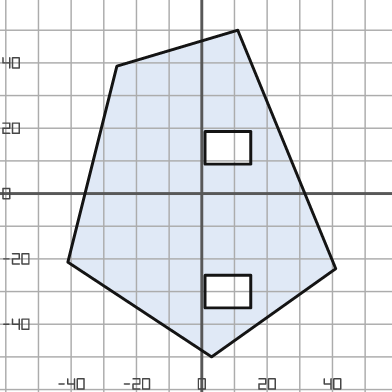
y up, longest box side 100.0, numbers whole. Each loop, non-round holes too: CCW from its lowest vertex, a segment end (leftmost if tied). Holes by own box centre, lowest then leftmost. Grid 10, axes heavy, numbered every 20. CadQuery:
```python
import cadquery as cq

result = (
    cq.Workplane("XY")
    .moveTo(3.0, -50.0)
    .lineTo(41.0, -23.0)
    .lineTo(11.0, 50.0)
    .lineTo(-26.0, 39.0)
    .lineTo(-41.0, -21.0)
    .close()
    .moveTo(1.0, -35.0)
    .lineTo(15.0, -35.0)
    .lineTo(15.0, -25.0)
    .lineTo(1.0, -25.0)
    .close()
    .moveTo(1.0, 9.0)
    .lineTo(15.0, 9.0)
    .lineTo(15.0, 19.0)
    .lineTo(1.0, 19.0)
    .close()
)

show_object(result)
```